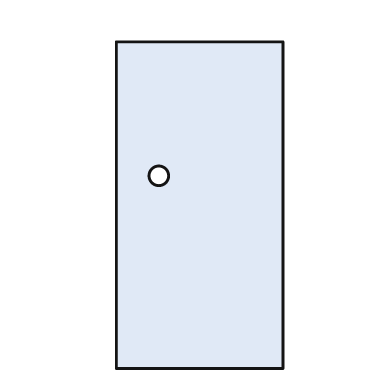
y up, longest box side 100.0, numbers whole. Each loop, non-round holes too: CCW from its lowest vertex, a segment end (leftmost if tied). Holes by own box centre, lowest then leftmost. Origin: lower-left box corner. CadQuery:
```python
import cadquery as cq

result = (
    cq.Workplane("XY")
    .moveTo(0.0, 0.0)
    .lineTo(51.0, 0.0)
    .lineTo(51.0, 100.0)
    .lineTo(0.0, 100.0)
    .close()
    .moveTo(13.0, 59.0)
    .circle(3.0)
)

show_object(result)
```